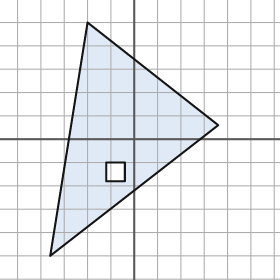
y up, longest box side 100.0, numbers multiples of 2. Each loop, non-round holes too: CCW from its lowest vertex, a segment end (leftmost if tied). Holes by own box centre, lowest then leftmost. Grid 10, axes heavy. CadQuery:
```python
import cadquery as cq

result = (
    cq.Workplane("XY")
    .moveTo(-36.0, -50.0)
    .lineTo(36.0, 6.0)
    .lineTo(-20.0, 50.0)
    .close()
    .moveTo(-12.0, -18.0)
    .lineTo(-4.0, -18.0)
    .lineTo(-4.0, -10.0)
    .lineTo(-12.0, -10.0)
    .close()
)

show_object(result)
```